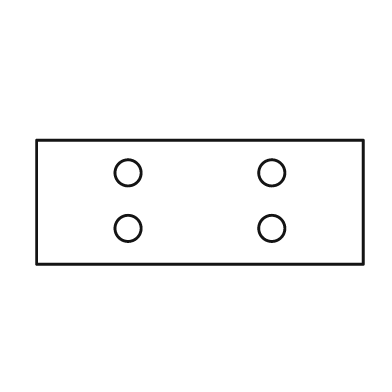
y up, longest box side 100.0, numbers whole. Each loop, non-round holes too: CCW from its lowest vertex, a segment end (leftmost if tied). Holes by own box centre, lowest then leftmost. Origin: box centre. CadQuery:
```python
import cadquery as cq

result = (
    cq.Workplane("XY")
    .moveTo(-50.0, -19.0)
    .lineTo(50.0, -19.0)
    .lineTo(50.0, 19.0)
    .lineTo(-50.0, 19.0)
    .close()
    .moveTo(-22.0, -8.0)
    .circle(4.0)
    .moveTo(22.0, -8.0)
    .circle(4.0)
    .moveTo(-22.0, 9.0)
    .circle(4.0)
    .moveTo(22.0, 9.0)
    .circle(4.0)
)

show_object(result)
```